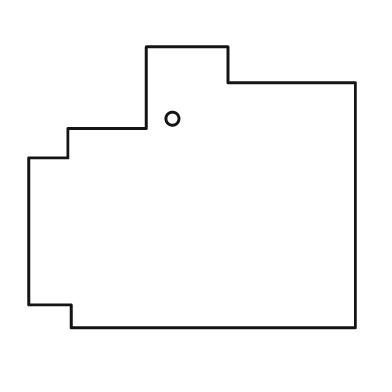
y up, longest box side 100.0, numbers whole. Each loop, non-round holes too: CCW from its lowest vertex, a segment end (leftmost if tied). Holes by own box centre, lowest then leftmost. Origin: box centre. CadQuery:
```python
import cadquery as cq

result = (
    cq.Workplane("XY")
    .moveTo(-37.0, -43.0)
    .lineTo(50.0, -43.0)
    .lineTo(50.0, 32.0)
    .lineTo(11.0, 32.0)
    .lineTo(11.0, 43.0)
    .lineTo(-14.0, 43.0)
    .lineTo(-14.0, 18.0)
    .lineTo(-38.0, 18.0)
    .lineTo(-38.0, 9.0)
    .lineTo(-50.0, 9.0)
    .lineTo(-50.0, -36.0)
    .lineTo(-37.0, -36.0)
    .close()
    .moveTo(-6.0, 21.0)
    .circle(2.0)
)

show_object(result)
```